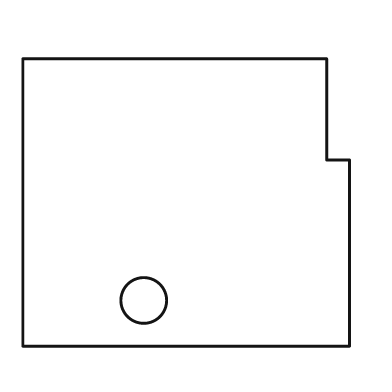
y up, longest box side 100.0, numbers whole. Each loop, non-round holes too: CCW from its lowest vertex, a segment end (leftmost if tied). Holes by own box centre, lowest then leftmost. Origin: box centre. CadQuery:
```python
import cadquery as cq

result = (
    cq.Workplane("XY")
    .moveTo(-50.0, -44.0)
    .lineTo(50.0, -44.0)
    .lineTo(50.0, 13.0)
    .lineTo(43.0, 13.0)
    .lineTo(43.0, 44.0)
    .lineTo(-50.0, 44.0)
    .close()
    .moveTo(-13.0, -30.0)
    .circle(7.0)
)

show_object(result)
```